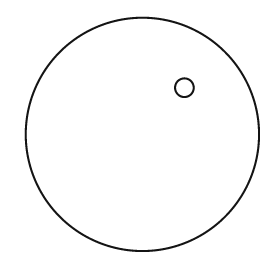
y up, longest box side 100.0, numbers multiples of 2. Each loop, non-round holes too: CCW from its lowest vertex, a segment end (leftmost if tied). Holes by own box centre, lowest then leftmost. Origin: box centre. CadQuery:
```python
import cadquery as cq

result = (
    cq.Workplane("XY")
    .moveTo(0.0, 0.0)
    .circle(50.0)
    .moveTo(18.0, 20.0)
    .circle(4.0)
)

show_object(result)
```